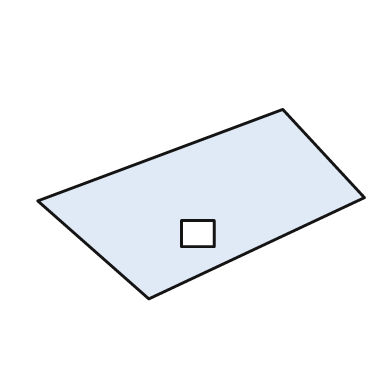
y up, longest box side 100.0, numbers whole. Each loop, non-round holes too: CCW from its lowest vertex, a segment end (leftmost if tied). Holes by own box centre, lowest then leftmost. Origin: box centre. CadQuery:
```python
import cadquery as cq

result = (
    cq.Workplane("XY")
    .moveTo(-16.0, -29.0)
    .lineTo(50.0, 2.0)
    .lineTo(25.0, 29.0)
    .lineTo(-50.0, 1.0)
    .close()
    .moveTo(-6.0, -13.0)
    .lineTo(4.0, -13.0)
    .lineTo(4.0, -5.0)
    .lineTo(-6.0, -5.0)
    .close()
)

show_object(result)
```